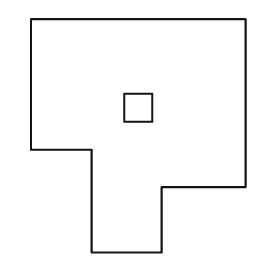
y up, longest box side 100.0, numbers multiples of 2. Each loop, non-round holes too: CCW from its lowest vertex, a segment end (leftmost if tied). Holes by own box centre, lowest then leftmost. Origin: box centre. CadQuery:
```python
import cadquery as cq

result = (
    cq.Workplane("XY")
    .moveTo(-20.0, -50.0)
    .lineTo(10.0, -50.0)
    .lineTo(10.0, -22.0)
    .lineTo(46.0, -22.0)
    .lineTo(46.0, 50.0)
    .lineTo(-46.0, 50.0)
    .lineTo(-46.0, -6.0)
    .lineTo(-20.0, -6.0)
    .close()
    .moveTo(-6.0, 6.0)
    .lineTo(6.0, 6.0)
    .lineTo(6.0, 18.0)
    .lineTo(-6.0, 18.0)
    .close()
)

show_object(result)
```